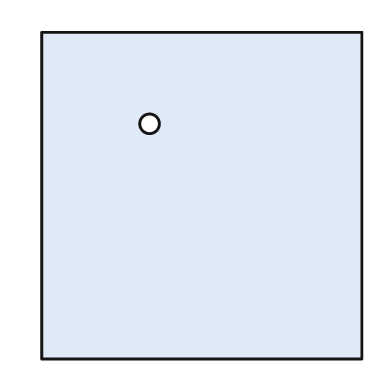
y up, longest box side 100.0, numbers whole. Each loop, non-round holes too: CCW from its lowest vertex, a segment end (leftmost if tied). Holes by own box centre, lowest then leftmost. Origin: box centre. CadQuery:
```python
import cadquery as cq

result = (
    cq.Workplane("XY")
    .moveTo(-49.0, -50.0)
    .lineTo(49.0, -50.0)
    .lineTo(49.0, 50.0)
    .lineTo(-49.0, 50.0)
    .close()
    .moveTo(-16.0, 22.0)
    .circle(3.0)
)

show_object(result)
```